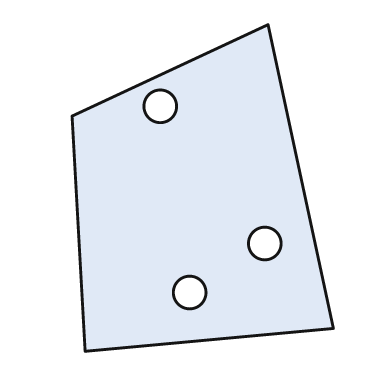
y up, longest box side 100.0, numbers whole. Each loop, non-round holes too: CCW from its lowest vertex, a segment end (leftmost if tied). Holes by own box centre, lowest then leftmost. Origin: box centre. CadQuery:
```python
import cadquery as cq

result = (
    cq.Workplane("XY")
    .moveTo(-36.0, -50.0)
    .lineTo(40.0, -43.0)
    .lineTo(20.0, 50.0)
    .lineTo(-40.0, 22.0)
    .close()
    .moveTo(-4.0, -32.0)
    .circle(5.0)
    .moveTo(19.0, -17.0)
    .circle(5.0)
    .moveTo(-13.0, 25.0)
    .circle(5.0)
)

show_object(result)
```